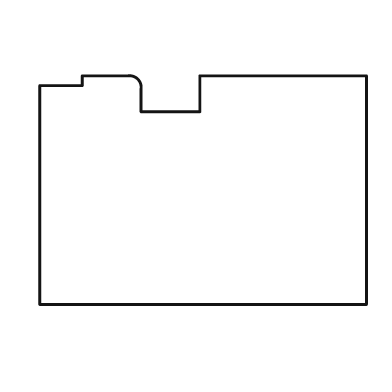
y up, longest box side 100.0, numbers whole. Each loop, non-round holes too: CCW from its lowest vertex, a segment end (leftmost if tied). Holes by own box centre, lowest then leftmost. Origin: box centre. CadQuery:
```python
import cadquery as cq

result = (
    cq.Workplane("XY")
    .moveTo(-50.0, -35.0)
    .lineTo(50.0, -35.0)
    .lineTo(50.0, 35.0)
    .lineTo(-1.0, 35.0)
    .lineTo(-1.0, 24.0)
    .lineTo(-19.0, 24.0)
    .lineTo(-19.0, 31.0)
    .threePointArc((-20.0, 34.0), (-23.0, 35.0))
    .lineTo(-37.0, 35.0)
    .lineTo(-37.0, 32.0)
    .lineTo(-50.0, 32.0)
    .close()
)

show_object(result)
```